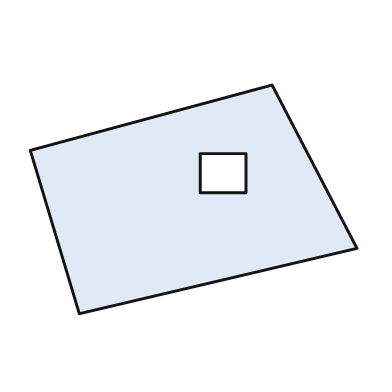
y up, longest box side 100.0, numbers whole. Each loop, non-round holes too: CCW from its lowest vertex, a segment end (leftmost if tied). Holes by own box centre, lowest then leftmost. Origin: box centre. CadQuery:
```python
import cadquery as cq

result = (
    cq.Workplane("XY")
    .moveTo(-35.0, -35.0)
    .lineTo(50.0, -15.0)
    .lineTo(24.0, 35.0)
    .lineTo(-50.0, 15.0)
    .close()
    .moveTo(2.0, 2.0)
    .lineTo(16.0, 2.0)
    .lineTo(16.0, 14.0)
    .lineTo(2.0, 14.0)
    .close()
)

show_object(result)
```